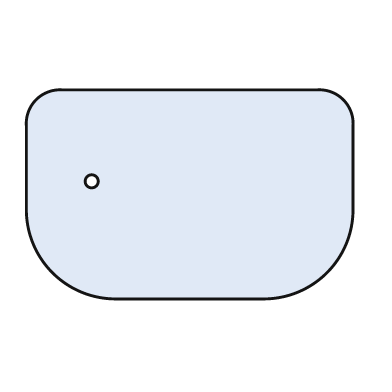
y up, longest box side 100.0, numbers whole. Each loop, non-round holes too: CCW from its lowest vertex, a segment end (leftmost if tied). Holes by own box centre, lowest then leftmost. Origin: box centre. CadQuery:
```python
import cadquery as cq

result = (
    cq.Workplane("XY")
    .moveTo(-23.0, -32.0)
    .lineTo(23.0, -32.0)
    .threePointArc((42.0, -24.0), (50.0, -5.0))
    .lineTo(50.0, 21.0)
    .threePointArc((47.0, 29.0), (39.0, 32.0))
    .lineTo(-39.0, 32.0)
    .threePointArc((-47.0, 29.0), (-50.0, 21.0))
    .lineTo(-50.0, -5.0)
    .threePointArc((-42.0, -24.0), (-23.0, -32.0))
    .close()
    .moveTo(-30.0, 4.0)
    .circle(2.0)
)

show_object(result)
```